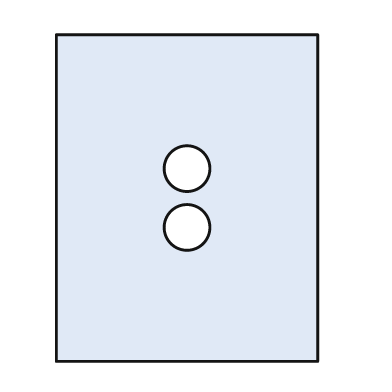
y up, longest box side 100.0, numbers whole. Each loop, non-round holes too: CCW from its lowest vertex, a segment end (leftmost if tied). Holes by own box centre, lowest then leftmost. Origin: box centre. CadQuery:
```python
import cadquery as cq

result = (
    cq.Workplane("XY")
    .moveTo(-40.0, -50.0)
    .lineTo(40.0, -50.0)
    .lineTo(40.0, 50.0)
    .lineTo(-40.0, 50.0)
    .close()
    .moveTo(0.0, -9.0)
    .circle(7.0)
    .moveTo(0.0, 9.0)
    .circle(7.0)
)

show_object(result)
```